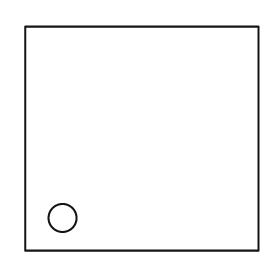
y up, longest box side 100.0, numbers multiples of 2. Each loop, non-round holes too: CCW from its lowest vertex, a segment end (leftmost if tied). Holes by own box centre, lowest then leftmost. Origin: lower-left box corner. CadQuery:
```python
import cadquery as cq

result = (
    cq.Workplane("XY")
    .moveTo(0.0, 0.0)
    .lineTo(100.0, 0.0)
    .lineTo(100.0, 96.0)
    .lineTo(0.0, 96.0)
    .close()
    .moveTo(16.0, 14.0)
    .circle(6.0)
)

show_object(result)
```